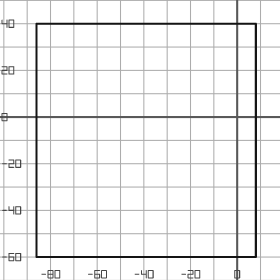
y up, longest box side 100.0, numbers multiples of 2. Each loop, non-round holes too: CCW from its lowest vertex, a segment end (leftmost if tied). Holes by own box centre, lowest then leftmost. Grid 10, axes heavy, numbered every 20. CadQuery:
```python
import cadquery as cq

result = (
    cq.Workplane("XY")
    .moveTo(-86.0, -60.0)
    .lineTo(8.0, -60.0)
    .lineTo(8.0, 40.0)
    .lineTo(-86.0, 40.0)
    .close()
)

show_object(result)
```